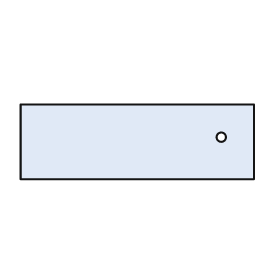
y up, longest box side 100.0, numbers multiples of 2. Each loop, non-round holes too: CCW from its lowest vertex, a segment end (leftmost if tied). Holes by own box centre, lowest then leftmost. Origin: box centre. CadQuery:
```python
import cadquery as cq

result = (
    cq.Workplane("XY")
    .moveTo(-50.0, -16.0)
    .lineTo(50.0, -16.0)
    .lineTo(50.0, 16.0)
    .lineTo(-50.0, 16.0)
    .close()
    .moveTo(36.0, 2.0)
    .circle(2.0)
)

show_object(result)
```